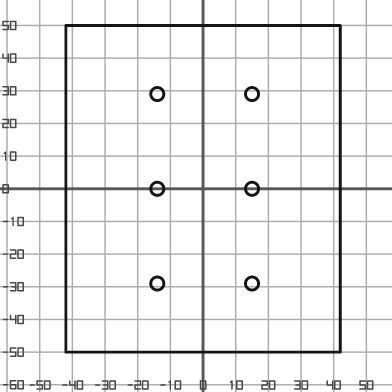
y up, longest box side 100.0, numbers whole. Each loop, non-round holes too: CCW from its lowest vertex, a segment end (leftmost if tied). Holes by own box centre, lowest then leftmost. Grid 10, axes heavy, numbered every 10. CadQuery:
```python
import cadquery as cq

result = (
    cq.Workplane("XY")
    .moveTo(-42.0, -50.0)
    .lineTo(42.0, -50.0)
    .lineTo(42.0, 50.0)
    .lineTo(-42.0, 50.0)
    .close()
    .moveTo(-14.0, -29.0)
    .circle(2.0)
    .moveTo(15.0, -29.0)
    .circle(2.0)
    .moveTo(-14.0, 0.0)
    .circle(2.0)
    .moveTo(15.0, 0.0)
    .circle(2.0)
    .moveTo(-14.0, 29.0)
    .circle(2.0)
    .moveTo(15.0, 29.0)
    .circle(2.0)
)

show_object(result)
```